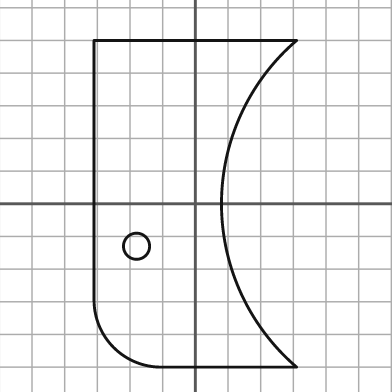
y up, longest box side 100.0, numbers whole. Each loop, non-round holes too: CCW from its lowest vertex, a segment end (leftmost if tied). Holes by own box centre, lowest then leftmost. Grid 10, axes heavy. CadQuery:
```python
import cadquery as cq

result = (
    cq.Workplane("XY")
    .moveTo(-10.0, -50.0)
    .lineTo(31.0, -50.0)
    .threePointArc((8.0, 0.0), (31.0, 50.0))
    .lineTo(-31.0, 50.0)
    .lineTo(-31.0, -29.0)
    .threePointArc((-25.0, -44.0), (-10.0, -50.0))
    .close()
    .moveTo(-18.0, -13.0)
    .circle(4.0)
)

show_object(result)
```